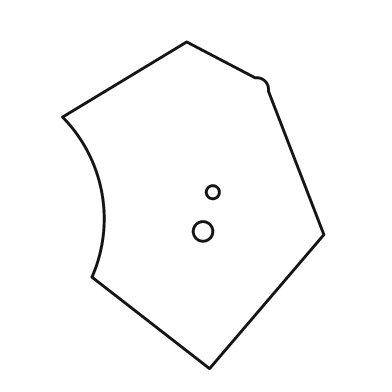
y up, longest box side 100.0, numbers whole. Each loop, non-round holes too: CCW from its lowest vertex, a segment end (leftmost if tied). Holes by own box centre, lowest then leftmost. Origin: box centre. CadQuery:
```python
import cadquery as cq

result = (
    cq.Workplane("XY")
    .moveTo(5.0, -50.0)
    .lineTo(40.0, -9.0)
    .lineTo(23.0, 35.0)
    .threePointArc((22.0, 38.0), (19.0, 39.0))
    .lineTo(-2.0, 50.0)
    .lineTo(-40.0, 27.0)
    .threePointArc((-28.0, 4.0), (-31.0, -22.0))
    .close()
    .moveTo(3.0, -8.0)
    .circle(3.0)
    .moveTo(6.0, 4.0)
    .circle(2.0)
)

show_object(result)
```